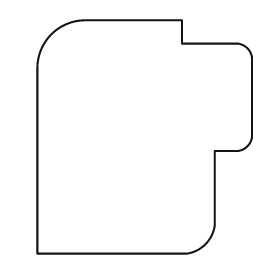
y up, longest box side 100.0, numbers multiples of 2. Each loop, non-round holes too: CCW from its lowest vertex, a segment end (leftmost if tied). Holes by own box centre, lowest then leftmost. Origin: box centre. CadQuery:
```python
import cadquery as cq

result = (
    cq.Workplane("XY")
    .moveTo(-46.0, -50.0)
    .lineTo(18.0, -50.0)
    .threePointArc((26.0, -46.0), (30.0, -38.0))
    .lineTo(30.0, -6.0)
    .lineTo(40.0, -6.0)
    .threePointArc((44.0, -4.0), (46.0, 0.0))
    .lineTo(46.0, 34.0)
    .threePointArc((44.0, 38.0), (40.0, 40.0))
    .lineTo(16.0, 40.0)
    .lineTo(16.0, 50.0)
    .lineTo(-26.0, 50.0)
    .threePointArc((-40.0, 44.0), (-46.0, 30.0))
    .close()
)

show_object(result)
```